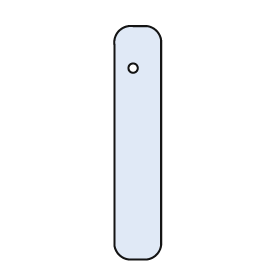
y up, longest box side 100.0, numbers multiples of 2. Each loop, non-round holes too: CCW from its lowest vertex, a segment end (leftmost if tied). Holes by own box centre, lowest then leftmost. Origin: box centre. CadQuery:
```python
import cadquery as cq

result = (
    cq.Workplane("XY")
    .moveTo(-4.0, -50.0)
    .lineTo(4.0, -50.0)
    .threePointArc((8.0, -48.0), (10.0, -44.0))
    .lineTo(10.0, 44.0)
    .threePointArc((8.0, 48.0), (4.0, 50.0))
    .lineTo(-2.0, 50.0)
    .threePointArc((-8.0, 48.0), (-10.0, 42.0))
    .lineTo(-10.0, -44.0)
    .threePointArc((-8.0, -48.0), (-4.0, -50.0))
    .close()
    .moveTo(-2.0, 32.0)
    .circle(2.0)
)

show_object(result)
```